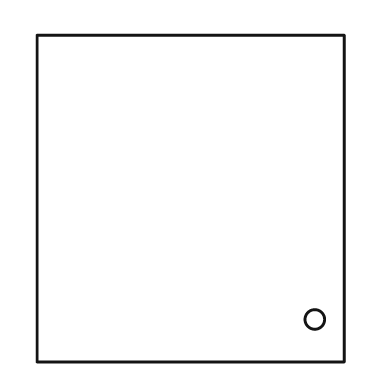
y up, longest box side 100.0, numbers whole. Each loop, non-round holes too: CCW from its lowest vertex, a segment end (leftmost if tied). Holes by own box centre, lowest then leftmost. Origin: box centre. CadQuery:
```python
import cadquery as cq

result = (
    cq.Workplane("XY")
    .moveTo(-47.0, -50.0)
    .lineTo(47.0, -50.0)
    .lineTo(47.0, 50.0)
    .lineTo(-47.0, 50.0)
    .close()
    .moveTo(38.0, -37.0)
    .circle(3.0)
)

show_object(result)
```